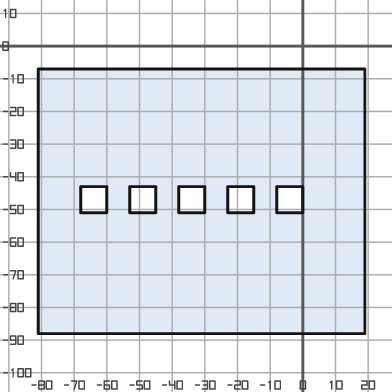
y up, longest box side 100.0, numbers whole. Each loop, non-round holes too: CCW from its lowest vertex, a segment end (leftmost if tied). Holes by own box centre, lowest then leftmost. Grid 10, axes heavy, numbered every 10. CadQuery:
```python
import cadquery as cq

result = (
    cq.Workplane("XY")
    .moveTo(-81.0, -88.0)
    .lineTo(19.0, -88.0)
    .lineTo(19.0, -7.0)
    .lineTo(-81.0, -7.0)
    .close()
    .moveTo(-68.0, -51.0)
    .lineTo(-60.0, -51.0)
    .lineTo(-60.0, -43.0)
    .lineTo(-68.0, -43.0)
    .close()
    .moveTo(-53.0, -51.0)
    .lineTo(-45.0, -51.0)
    .lineTo(-45.0, -43.0)
    .lineTo(-53.0, -43.0)
    .close()
    .moveTo(-38.0, -51.0)
    .lineTo(-30.0, -51.0)
    .lineTo(-30.0, -43.0)
    .lineTo(-38.0, -43.0)
    .close()
    .moveTo(-23.0, -51.0)
    .lineTo(-15.0, -51.0)
    .lineTo(-15.0, -43.0)
    .lineTo(-23.0, -43.0)
    .close()
    .moveTo(-8.0, -51.0)
    .lineTo(0.0, -51.0)
    .lineTo(0.0, -43.0)
    .lineTo(-8.0, -43.0)
    .close()
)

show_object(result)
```